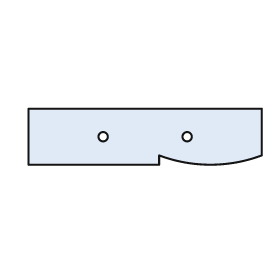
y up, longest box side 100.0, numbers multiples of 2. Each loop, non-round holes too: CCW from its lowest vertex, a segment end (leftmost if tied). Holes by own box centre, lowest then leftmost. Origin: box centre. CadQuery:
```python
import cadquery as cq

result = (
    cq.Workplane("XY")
    .moveTo(-50.0, -12.0)
    .lineTo(6.0, -12.0)
    .lineTo(6.0, -8.0)
    .threePointArc((28.0, -12.0), (50.0, -8.0))
    .lineTo(50.0, 12.0)
    .lineTo(-50.0, 12.0)
    .close()
    .moveTo(-18.0, 0.0)
    .circle(2.0)
    .moveTo(18.0, 0.0)
    .circle(2.0)
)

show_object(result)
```